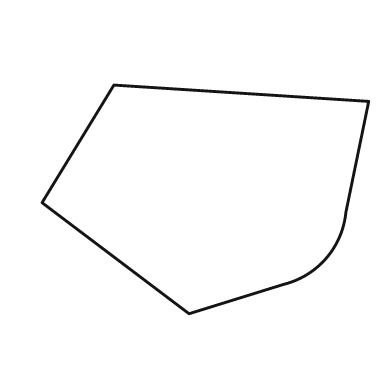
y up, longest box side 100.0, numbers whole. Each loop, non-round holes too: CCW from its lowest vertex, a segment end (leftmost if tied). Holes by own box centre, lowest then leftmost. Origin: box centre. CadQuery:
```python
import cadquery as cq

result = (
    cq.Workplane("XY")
    .moveTo(-5.0, -35.0)
    .lineTo(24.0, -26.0)
    .threePointArc((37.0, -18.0), (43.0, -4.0))
    .lineTo(50.0, 30.0)
    .lineTo(-28.0, 35.0)
    .lineTo(-50.0, -1.0)
    .close()
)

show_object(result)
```